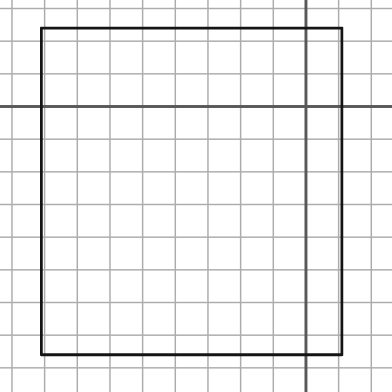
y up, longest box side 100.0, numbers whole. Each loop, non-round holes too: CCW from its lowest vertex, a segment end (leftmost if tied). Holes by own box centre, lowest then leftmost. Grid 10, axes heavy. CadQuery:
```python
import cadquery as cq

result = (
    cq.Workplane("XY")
    .moveTo(-81.0, -76.0)
    .lineTo(11.0, -76.0)
    .lineTo(11.0, 24.0)
    .lineTo(-81.0, 24.0)
    .close()
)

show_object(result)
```